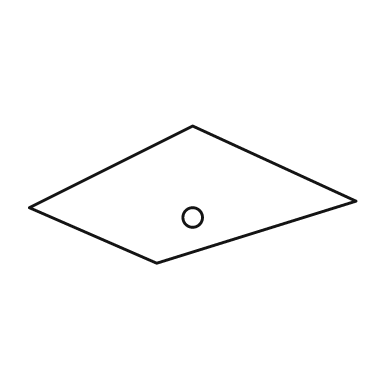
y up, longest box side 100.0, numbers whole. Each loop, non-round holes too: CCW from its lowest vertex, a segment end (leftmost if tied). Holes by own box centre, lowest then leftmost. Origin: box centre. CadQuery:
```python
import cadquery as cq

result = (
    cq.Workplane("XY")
    .moveTo(-11.0, -21.0)
    .lineTo(50.0, -2.0)
    .lineTo(0.0, 21.0)
    .lineTo(-50.0, -4.0)
    .close()
    .moveTo(0.0, -7.0)
    .circle(3.0)
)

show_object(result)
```